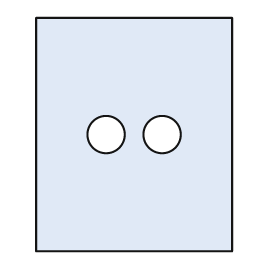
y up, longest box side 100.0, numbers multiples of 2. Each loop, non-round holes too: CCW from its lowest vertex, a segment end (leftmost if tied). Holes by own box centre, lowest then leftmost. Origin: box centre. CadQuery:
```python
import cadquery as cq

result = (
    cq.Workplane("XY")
    .moveTo(-42.0, -50.0)
    .lineTo(42.0, -50.0)
    .lineTo(42.0, 50.0)
    .lineTo(-42.0, 50.0)
    .close()
    .moveTo(-12.0, 0.0)
    .circle(8.0)
    .moveTo(12.0, 0.0)
    .circle(8.0)
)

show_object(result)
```